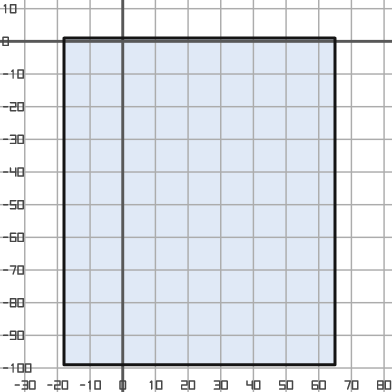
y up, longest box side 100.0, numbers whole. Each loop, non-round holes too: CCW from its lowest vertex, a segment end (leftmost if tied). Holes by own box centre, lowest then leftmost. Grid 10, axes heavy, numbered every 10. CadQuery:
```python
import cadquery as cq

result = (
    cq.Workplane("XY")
    .moveTo(-18.0, -99.0)
    .lineTo(65.0, -99.0)
    .lineTo(65.0, 1.0)
    .lineTo(-18.0, 1.0)
    .close()
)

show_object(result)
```